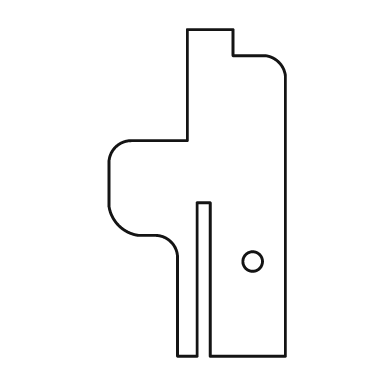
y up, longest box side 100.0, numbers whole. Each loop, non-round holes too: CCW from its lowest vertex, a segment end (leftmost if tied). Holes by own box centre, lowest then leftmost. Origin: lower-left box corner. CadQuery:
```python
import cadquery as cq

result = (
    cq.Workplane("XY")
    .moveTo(21.0, 0.0)
    .lineTo(27.0, 0.0)
    .lineTo(27.0, 47.0)
    .lineTo(31.0, 47.0)
    .lineTo(31.0, 0.0)
    .lineTo(54.0, 0.0)
    .lineTo(54.0, 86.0)
    .threePointArc((52.0, 90.0), (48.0, 92.0))
    .lineTo(38.0, 92.0)
    .lineTo(38.0, 100.0)
    .lineTo(24.0, 100.0)
    .lineTo(24.0, 66.0)
    .lineTo(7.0, 66.0)
    .threePointArc((2.0, 64.0), (0.0, 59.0))
    .lineTo(0.0, 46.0)
    .threePointArc((3.0, 40.0), (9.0, 37.0))
    .lineTo(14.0, 37.0)
    .threePointArc((19.0, 35.0), (21.0, 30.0))
    .close()
    .moveTo(44.0, 29.0)
    .circle(3.0)
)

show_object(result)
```